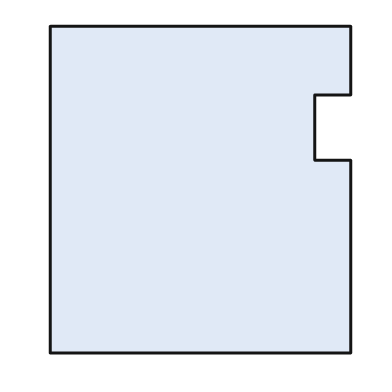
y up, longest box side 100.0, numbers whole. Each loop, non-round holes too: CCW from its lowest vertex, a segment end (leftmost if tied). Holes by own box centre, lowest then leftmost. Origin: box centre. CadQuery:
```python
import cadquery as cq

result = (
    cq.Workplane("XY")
    .moveTo(-46.0, -50.0)
    .lineTo(46.0, -50.0)
    .lineTo(46.0, 9.0)
    .lineTo(35.0, 9.0)
    .lineTo(35.0, 29.0)
    .lineTo(46.0, 29.0)
    .lineTo(46.0, 50.0)
    .lineTo(-46.0, 50.0)
    .close()
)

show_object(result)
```